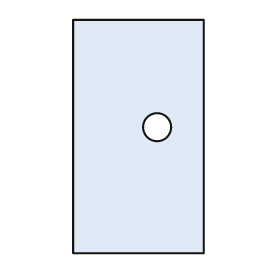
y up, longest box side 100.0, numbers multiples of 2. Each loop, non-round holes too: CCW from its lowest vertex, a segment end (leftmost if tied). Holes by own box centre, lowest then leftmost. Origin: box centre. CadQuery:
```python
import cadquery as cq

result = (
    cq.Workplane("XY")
    .moveTo(-28.0, -50.0)
    .lineTo(28.0, -50.0)
    .lineTo(28.0, 50.0)
    .lineTo(-28.0, 50.0)
    .close()
    .moveTo(8.0, 4.0)
    .circle(6.0)
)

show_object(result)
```